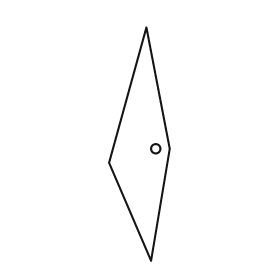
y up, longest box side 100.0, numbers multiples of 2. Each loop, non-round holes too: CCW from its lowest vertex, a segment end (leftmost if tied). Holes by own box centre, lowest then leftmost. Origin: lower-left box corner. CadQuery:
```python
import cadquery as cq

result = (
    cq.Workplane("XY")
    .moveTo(18.0, 0.0)
    .lineTo(26.0, 48.0)
    .lineTo(16.0, 100.0)
    .lineTo(0.0, 42.0)
    .close()
    .moveTo(20.0, 48.0)
    .circle(2.0)
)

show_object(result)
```